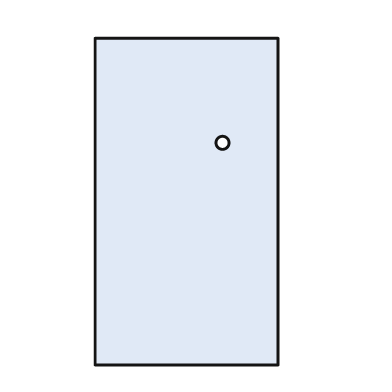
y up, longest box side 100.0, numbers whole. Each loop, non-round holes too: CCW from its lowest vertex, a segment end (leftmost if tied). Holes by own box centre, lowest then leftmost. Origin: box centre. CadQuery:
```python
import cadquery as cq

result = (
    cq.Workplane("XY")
    .moveTo(-28.0, -50.0)
    .lineTo(28.0, -50.0)
    .lineTo(28.0, 50.0)
    .lineTo(-28.0, 50.0)
    .close()
    .moveTo(11.0, 18.0)
    .circle(2.0)
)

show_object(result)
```